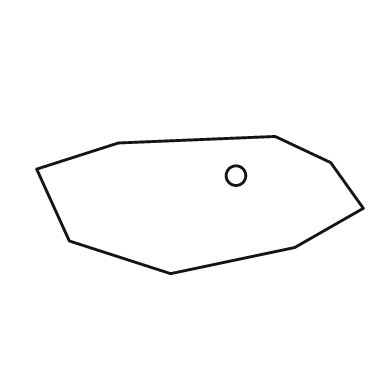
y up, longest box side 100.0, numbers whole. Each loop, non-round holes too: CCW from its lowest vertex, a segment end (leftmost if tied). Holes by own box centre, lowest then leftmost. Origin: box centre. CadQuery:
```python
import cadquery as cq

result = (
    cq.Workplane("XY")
    .moveTo(-9.0, -21.0)
    .lineTo(29.0, -13.0)
    .lineTo(50.0, -1.0)
    .lineTo(40.0, 13.0)
    .lineTo(23.0, 21.0)
    .lineTo(-25.0, 19.0)
    .lineTo(-50.0, 11.0)
    .lineTo(-40.0, -11.0)
    .close()
    .moveTo(11.0, 9.0)
    .circle(3.0)
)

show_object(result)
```